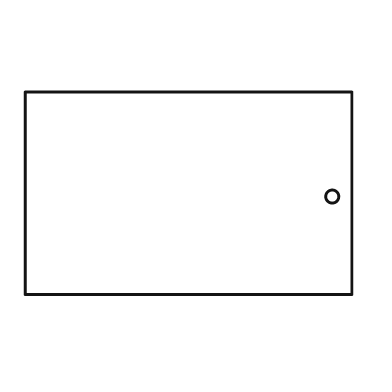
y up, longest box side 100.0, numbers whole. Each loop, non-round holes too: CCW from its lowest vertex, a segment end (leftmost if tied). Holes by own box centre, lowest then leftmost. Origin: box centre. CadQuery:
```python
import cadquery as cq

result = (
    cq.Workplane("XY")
    .moveTo(-50.0, -31.0)
    .lineTo(50.0, -31.0)
    .lineTo(50.0, 31.0)
    .lineTo(-50.0, 31.0)
    .close()
    .moveTo(44.0, -1.0)
    .circle(2.0)
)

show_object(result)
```